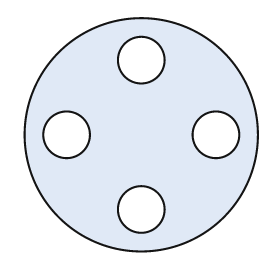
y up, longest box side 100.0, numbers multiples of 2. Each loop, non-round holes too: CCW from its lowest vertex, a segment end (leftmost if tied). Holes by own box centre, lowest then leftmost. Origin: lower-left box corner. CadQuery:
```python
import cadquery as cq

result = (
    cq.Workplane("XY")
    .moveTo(50.0, 50.0)
    .circle(50.0)
    .moveTo(50.0, 18.0)
    .circle(10.0)
    .moveTo(18.0, 50.0)
    .circle(10.0)
    .moveTo(82.0, 50.0)
    .circle(10.0)
    .moveTo(50.0, 82.0)
    .circle(10.0)
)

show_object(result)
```